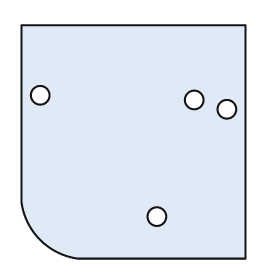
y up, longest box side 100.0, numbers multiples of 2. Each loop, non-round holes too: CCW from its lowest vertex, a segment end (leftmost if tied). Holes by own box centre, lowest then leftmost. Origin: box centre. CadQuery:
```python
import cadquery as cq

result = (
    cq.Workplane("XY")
    .moveTo(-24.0, -50.0)
    .lineTo(48.0, -50.0)
    .lineTo(48.0, 50.0)
    .lineTo(-48.0, 50.0)
    .lineTo(-48.0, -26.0)
    .threePointArc((-40.0, -42.0), (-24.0, -50.0))
    .close()
    .moveTo(10.0, -32.0)
    .circle(4.0)
    .moveTo(40.0, 14.0)
    .circle(4.0)
    .moveTo(26.0, 18.0)
    .circle(4.0)
    .moveTo(-40.0, 20.0)
    .circle(4.0)
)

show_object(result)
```